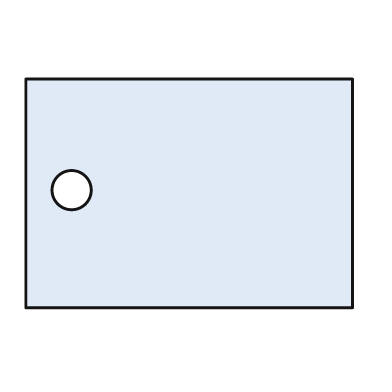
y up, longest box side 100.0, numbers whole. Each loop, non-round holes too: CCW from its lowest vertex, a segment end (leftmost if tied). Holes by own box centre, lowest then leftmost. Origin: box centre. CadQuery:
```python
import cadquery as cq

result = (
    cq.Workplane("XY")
    .moveTo(-50.0, -35.0)
    .lineTo(50.0, -35.0)
    .lineTo(50.0, 35.0)
    .lineTo(-50.0, 35.0)
    .close()
    .moveTo(-36.0, 1.0)
    .circle(6.0)
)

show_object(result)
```